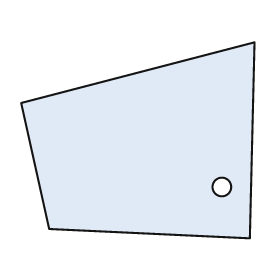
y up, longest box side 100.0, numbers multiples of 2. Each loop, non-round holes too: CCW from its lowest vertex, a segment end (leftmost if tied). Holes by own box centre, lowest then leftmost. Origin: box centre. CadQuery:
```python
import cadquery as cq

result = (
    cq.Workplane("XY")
    .moveTo(48.0, -42.0)
    .lineTo(50.0, 42.0)
    .lineTo(-50.0, 16.0)
    .lineTo(-38.0, -38.0)
    .close()
    .moveTo(36.0, -20.0)
    .circle(4.0)
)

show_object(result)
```